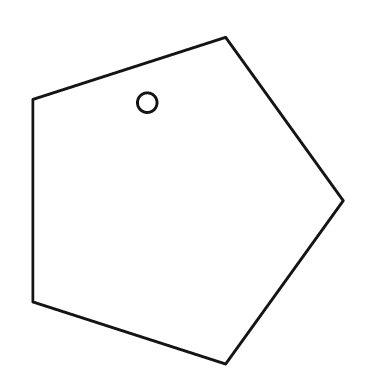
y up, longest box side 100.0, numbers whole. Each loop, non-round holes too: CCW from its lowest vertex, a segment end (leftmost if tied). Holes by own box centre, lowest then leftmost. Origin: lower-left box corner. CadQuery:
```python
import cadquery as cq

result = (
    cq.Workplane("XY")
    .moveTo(59.0, 0.0)
    .lineTo(95.0, 50.0)
    .lineTo(59.0, 100.0)
    .lineTo(0.0, 81.0)
    .lineTo(0.0, 19.0)
    .close()
    .moveTo(35.0, 80.0)
    .circle(3.0)
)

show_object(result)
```